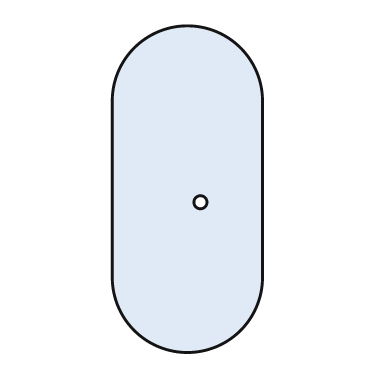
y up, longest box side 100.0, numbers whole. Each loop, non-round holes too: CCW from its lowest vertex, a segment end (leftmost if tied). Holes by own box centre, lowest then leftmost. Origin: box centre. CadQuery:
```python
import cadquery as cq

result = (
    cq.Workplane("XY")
    .moveTo(-23.0, -27.0)
    .threePointArc((0.0, -50.0), (23.0, -27.0))
    .lineTo(23.0, 27.0)
    .threePointArc((0.0, 50.0), (-23.0, 27.0))
    .close()
    .moveTo(4.0, -4.0)
    .circle(2.0)
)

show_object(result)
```